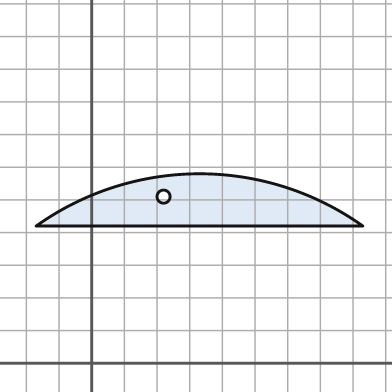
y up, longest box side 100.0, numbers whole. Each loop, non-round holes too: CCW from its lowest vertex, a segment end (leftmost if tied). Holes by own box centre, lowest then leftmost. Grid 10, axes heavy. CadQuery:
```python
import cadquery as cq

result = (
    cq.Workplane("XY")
    .moveTo(-17.0, 42.0)
    .lineTo(83.0, 42.0)
    .threePointArc((33.0, 58.0), (-17.0, 42.0))
    .close()
    .moveTo(22.0, 51.0)
    .circle(2.0)
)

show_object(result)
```